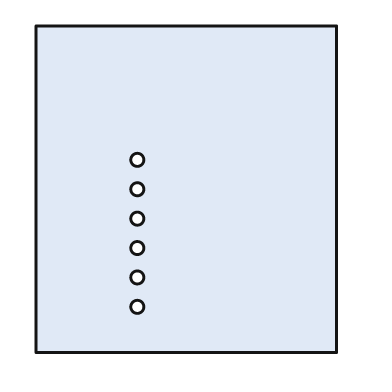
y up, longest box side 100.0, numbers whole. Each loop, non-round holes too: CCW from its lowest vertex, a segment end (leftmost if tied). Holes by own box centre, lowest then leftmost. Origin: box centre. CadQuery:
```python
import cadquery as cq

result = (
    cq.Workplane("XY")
    .moveTo(-46.0, -50.0)
    .lineTo(46.0, -50.0)
    .lineTo(46.0, 50.0)
    .lineTo(-46.0, 50.0)
    .close()
    .moveTo(-15.0, -36.0)
    .circle(2.0)
    .moveTo(-15.0, -27.0)
    .circle(2.0)
    .moveTo(-15.0, -18.0)
    .circle(2.0)
    .moveTo(-15.0, -9.0)
    .circle(2.0)
    .moveTo(-15.0, 0.0)
    .circle(2.0)
    .moveTo(-15.0, 9.0)
    .circle(2.0)
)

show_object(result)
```